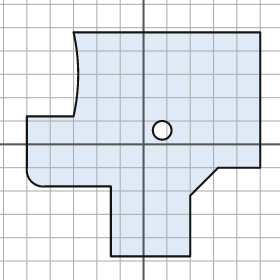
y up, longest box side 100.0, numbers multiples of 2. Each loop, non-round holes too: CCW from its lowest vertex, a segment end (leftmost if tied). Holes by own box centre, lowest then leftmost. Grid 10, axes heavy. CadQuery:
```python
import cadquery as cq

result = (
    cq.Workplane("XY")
    .moveTo(-14.0, -48.0)
    .lineTo(20.0, -48.0)
    .lineTo(20.0, -22.0)
    .lineTo(32.0, -10.0)
    .lineTo(50.0, -10.0)
    .lineTo(50.0, 48.0)
    .lineTo(-30.0, 48.0)
    .threePointArc((-28.0, 30.0), (-30.0, 12.0))
    .lineTo(-50.0, 12.0)
    .lineTo(-50.0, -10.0)
    .threePointArc((-48.0, -16.0), (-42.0, -18.0))
    .lineTo(-14.0, -18.0)
    .close()
    .moveTo(8.0, 6.0)
    .circle(4.0)
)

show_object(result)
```